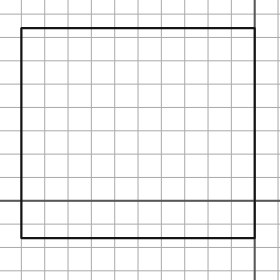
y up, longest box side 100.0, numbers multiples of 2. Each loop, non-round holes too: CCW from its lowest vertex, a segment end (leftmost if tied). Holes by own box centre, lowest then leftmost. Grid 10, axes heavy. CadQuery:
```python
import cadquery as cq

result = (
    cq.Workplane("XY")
    .moveTo(-100.0, -16.0)
    .lineTo(0.0, -16.0)
    .lineTo(0.0, 74.0)
    .lineTo(-100.0, 74.0)
    .close()
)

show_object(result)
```